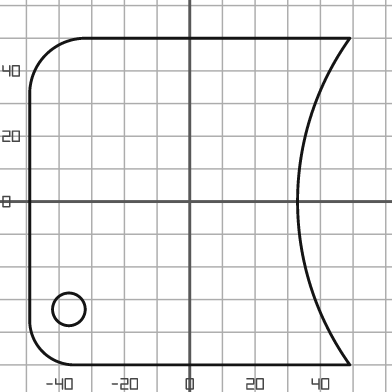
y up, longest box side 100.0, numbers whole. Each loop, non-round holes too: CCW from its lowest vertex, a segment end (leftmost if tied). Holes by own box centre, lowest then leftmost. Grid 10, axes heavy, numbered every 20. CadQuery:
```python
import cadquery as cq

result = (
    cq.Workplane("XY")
    .moveTo(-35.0, -50.0)
    .lineTo(49.0, -50.0)
    .threePointArc((33.0, 0.0), (49.0, 50.0))
    .lineTo(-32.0, 50.0)
    .threePointArc((-44.0, 45.0), (-49.0, 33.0))
    .lineTo(-49.0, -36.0)
    .threePointArc((-45.0, -46.0), (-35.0, -50.0))
    .close()
    .moveTo(-37.0, -33.0)
    .circle(5.0)
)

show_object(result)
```